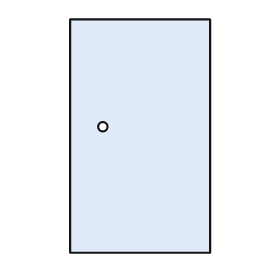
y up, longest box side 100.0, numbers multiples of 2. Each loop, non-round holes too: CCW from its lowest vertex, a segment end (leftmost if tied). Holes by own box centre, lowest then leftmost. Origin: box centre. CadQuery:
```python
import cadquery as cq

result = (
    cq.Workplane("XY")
    .moveTo(-30.0, -50.0)
    .lineTo(30.0, -50.0)
    .lineTo(30.0, 50.0)
    .lineTo(-30.0, 50.0)
    .close()
    .moveTo(-16.0, 4.0)
    .circle(2.0)
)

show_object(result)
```